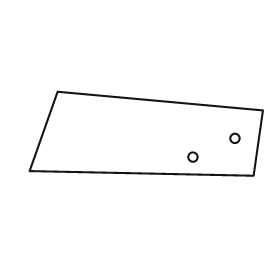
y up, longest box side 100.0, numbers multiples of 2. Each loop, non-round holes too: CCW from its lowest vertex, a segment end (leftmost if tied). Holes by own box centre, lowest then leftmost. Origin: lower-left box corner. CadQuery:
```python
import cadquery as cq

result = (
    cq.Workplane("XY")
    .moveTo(96.0, 0.0)
    .lineTo(100.0, 28.0)
    .lineTo(12.0, 36.0)
    .lineTo(0.0, 2.0)
    .close()
    .moveTo(70.0, 8.0)
    .circle(2.0)
    .moveTo(88.0, 16.0)
    .circle(2.0)
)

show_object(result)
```